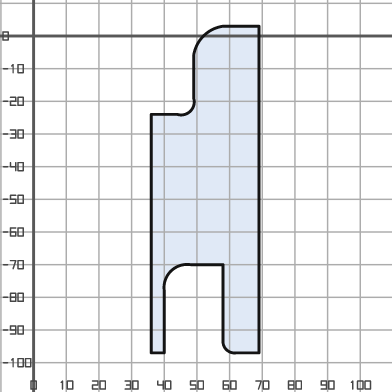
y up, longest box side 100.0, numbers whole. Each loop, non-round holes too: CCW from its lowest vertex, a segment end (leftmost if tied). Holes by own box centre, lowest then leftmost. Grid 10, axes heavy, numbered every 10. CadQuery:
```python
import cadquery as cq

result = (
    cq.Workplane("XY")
    .moveTo(36.0, -97.0)
    .lineTo(40.0, -97.0)
    .lineTo(40.0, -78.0)
    .threePointArc((42.0, -72.0), (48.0, -70.0))
    .lineTo(58.0, -70.0)
    .lineTo(58.0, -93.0)
    .threePointArc((59.0, -96.0), (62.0, -97.0))
    .lineTo(69.0, -97.0)
    .lineTo(69.0, 3.0)
    .lineTo(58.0, 3.0)
    .threePointArc((52.0, 0.0), (49.0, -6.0))
    .lineTo(49.0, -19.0)
    .threePointArc((48.0, -23.0), (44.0, -24.0))
    .lineTo(36.0, -24.0)
    .close()
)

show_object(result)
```